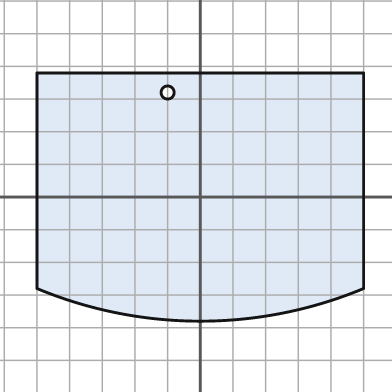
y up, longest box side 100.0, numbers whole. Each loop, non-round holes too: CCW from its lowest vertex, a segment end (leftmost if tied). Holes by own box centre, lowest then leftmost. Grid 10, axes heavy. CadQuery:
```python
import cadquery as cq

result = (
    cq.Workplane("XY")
    .moveTo(-50.0, -28.0)
    .threePointArc((0.0, -38.0), (50.0, -28.0))
    .lineTo(50.0, 38.0)
    .lineTo(-50.0, 38.0)
    .close()
    .moveTo(-10.0, 32.0)
    .circle(2.0)
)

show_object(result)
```